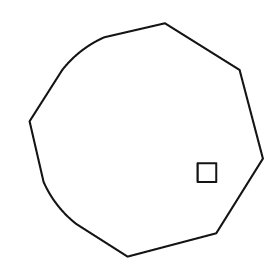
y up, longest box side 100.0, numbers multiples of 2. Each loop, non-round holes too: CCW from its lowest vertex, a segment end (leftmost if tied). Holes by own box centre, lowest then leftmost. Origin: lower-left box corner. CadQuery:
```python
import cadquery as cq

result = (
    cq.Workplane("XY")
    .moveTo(42.0, 0.0)
    .lineTo(80.0, 10.0)
    .lineTo(100.0, 42.0)
    .lineTo(90.0, 80.0)
    .lineTo(58.0, 100.0)
    .lineTo(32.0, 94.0)
    .threePointArc((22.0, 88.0), (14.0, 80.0))
    .lineTo(0.0, 58.0)
    .lineTo(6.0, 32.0)
    .threePointArc((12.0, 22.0), (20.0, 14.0))
    .close()
    .moveTo(72.0, 32.0)
    .lineTo(80.0, 32.0)
    .lineTo(80.0, 40.0)
    .lineTo(72.0, 40.0)
    .close()
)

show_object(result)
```